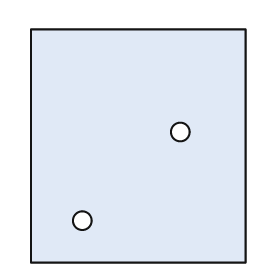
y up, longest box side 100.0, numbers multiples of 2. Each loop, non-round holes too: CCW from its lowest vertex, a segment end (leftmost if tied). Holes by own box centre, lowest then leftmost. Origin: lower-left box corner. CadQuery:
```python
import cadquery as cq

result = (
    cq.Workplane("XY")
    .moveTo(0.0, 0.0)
    .lineTo(92.0, 0.0)
    .lineTo(92.0, 100.0)
    .lineTo(0.0, 100.0)
    .close()
    .moveTo(22.0, 18.0)
    .circle(4.0)
    .moveTo(64.0, 56.0)
    .circle(4.0)
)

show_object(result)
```